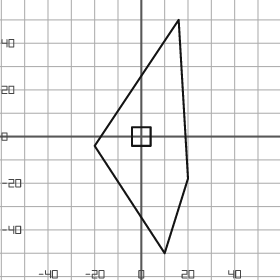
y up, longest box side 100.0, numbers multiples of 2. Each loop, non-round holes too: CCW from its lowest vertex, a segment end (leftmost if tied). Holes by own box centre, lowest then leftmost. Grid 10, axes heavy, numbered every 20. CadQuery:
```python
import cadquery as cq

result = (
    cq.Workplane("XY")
    .moveTo(10.0, -50.0)
    .lineTo(20.0, -18.0)
    .lineTo(16.0, 50.0)
    .lineTo(-20.0, -4.0)
    .close()
    .moveTo(-4.0, -4.0)
    .lineTo(4.0, -4.0)
    .lineTo(4.0, 4.0)
    .lineTo(-4.0, 4.0)
    .close()
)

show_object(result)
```